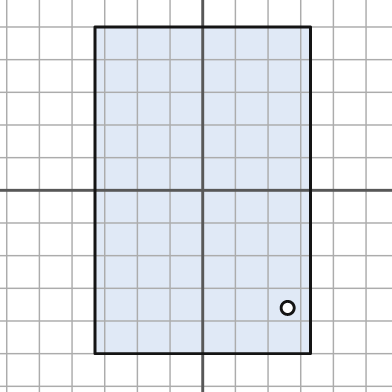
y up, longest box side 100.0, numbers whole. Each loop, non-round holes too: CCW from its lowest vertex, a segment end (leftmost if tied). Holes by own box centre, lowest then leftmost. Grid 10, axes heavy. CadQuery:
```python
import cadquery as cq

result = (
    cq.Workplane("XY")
    .moveTo(-33.0, -50.0)
    .lineTo(33.0, -50.0)
    .lineTo(33.0, 50.0)
    .lineTo(-33.0, 50.0)
    .close()
    .moveTo(26.0, -36.0)
    .circle(2.0)
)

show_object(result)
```